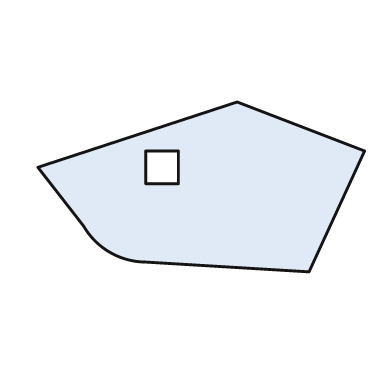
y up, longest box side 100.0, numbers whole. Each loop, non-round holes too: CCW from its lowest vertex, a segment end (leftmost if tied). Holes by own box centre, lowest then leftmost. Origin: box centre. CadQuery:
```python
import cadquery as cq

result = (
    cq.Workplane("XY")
    .moveTo(33.0, -26.0)
    .lineTo(50.0, 11.0)
    .lineTo(11.0, 26.0)
    .lineTo(-50.0, 6.0)
    .lineTo(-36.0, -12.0)
    .threePointArc((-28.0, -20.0), (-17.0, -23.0))
    .close()
    .moveTo(-17.0, 1.0)
    .lineTo(-7.0, 1.0)
    .lineTo(-7.0, 11.0)
    .lineTo(-17.0, 11.0)
    .close()
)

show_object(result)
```